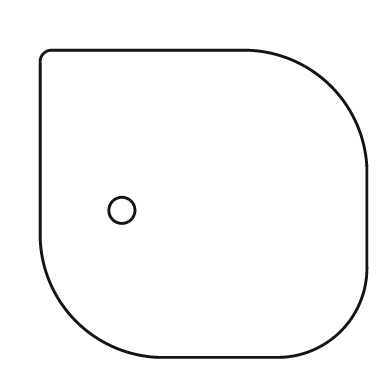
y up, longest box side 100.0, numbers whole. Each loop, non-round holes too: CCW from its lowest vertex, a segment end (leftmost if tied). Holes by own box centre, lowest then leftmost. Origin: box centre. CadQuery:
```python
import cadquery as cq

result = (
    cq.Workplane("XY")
    .moveTo(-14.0, -47.0)
    .lineTo(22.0, -47.0)
    .threePointArc((42.0, -39.0), (50.0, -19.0))
    .lineTo(50.0, 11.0)
    .threePointArc((39.0, 36.0), (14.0, 47.0))
    .lineTo(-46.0, 47.0)
    .threePointArc((-49.0, 46.0), (-50.0, 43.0))
    .lineTo(-50.0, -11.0)
    .threePointArc((-39.0, -36.0), (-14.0, -47.0))
    .close()
    .moveTo(-25.0, -2.0)
    .circle(4.0)
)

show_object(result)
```